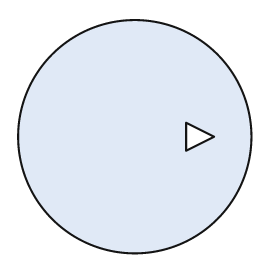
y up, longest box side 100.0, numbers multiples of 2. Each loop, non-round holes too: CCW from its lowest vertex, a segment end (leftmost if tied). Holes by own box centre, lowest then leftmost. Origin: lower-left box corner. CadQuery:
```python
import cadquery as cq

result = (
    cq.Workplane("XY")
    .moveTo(50.0, 50.0)
    .circle(50.0)
    .moveTo(72.0, 44.0)
    .lineTo(84.0, 50.0)
    .lineTo(72.0, 56.0)
    .close()
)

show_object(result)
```